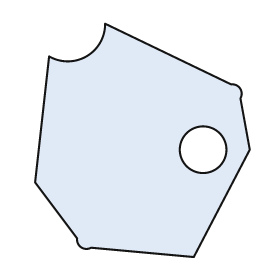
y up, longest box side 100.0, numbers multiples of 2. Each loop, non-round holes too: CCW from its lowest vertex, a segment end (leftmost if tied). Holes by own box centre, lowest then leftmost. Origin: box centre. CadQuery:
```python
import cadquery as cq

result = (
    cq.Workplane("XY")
    .moveTo(22.0, -50.0)
    .lineTo(46.0, -4.0)
    .lineTo(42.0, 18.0)
    .threePointArc((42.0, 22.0), (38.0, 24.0))
    .lineTo(-16.0, 50.0)
    .threePointArc((-24.0, 36.0), (-40.0, 36.0))
    .lineTo(-46.0, -18.0)
    .lineTo(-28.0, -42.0)
    .threePointArc((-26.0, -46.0), (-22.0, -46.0))
    .close()
    .moveTo(26.0, -4.0)
    .circle(10.0)
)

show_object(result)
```